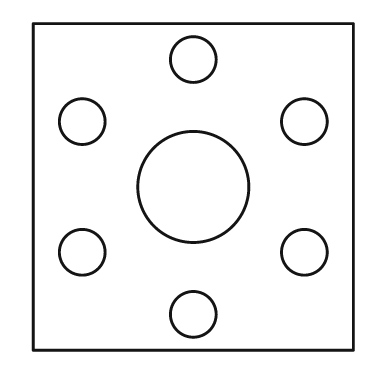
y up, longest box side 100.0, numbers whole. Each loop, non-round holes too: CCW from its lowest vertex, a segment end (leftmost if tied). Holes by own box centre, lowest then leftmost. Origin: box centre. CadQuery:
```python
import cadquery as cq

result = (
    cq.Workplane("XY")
    .moveTo(-49.0, -50.0)
    .lineTo(49.0, -50.0)
    .lineTo(49.0, 50.0)
    .lineTo(-49.0, 50.0)
    .close()
    .moveTo(0.0, -39.0)
    .circle(7.0)
    .moveTo(-34.0, -20.0)
    .circle(7.0)
    .moveTo(34.0, -20.0)
    .circle(7.0)
    .moveTo(0.0, 0.0)
    .circle(17.0)
    .moveTo(-34.0, 20.0)
    .circle(7.0)
    .moveTo(34.0, 20.0)
    .circle(7.0)
    .moveTo(0.0, 39.0)
    .circle(7.0)
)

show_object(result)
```